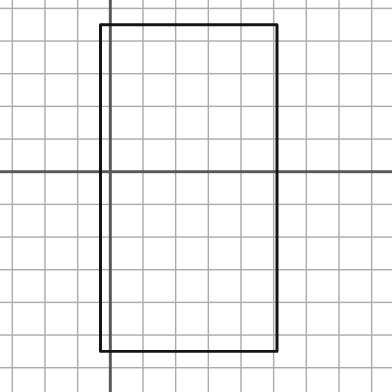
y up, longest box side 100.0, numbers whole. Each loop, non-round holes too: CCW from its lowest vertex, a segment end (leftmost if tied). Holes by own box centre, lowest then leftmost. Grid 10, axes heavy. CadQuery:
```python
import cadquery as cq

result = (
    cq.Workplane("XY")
    .moveTo(-3.0, -55.0)
    .lineTo(51.0, -55.0)
    .lineTo(51.0, 45.0)
    .lineTo(-3.0, 45.0)
    .close()
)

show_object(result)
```